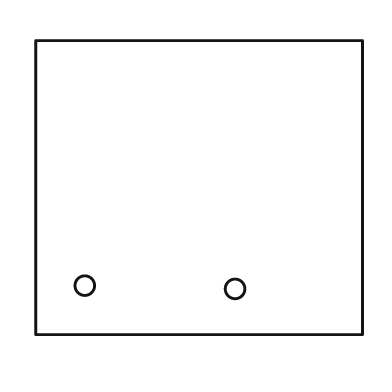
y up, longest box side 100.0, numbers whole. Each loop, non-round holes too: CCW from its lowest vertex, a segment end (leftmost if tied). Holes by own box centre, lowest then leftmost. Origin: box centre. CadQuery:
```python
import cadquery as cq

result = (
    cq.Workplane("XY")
    .moveTo(-50.0, -45.0)
    .lineTo(50.0, -45.0)
    .lineTo(50.0, 45.0)
    .lineTo(-50.0, 45.0)
    .close()
    .moveTo(11.0, -31.0)
    .circle(3.0)
    .moveTo(-35.0, -30.0)
    .circle(3.0)
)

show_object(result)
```